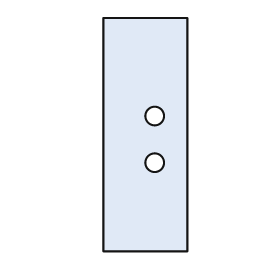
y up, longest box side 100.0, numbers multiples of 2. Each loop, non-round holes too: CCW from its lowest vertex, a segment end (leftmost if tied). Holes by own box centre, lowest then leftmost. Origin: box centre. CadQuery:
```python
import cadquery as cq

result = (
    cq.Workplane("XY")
    .moveTo(-18.0, -50.0)
    .lineTo(18.0, -50.0)
    .lineTo(18.0, 50.0)
    .lineTo(-18.0, 50.0)
    .close()
    .moveTo(4.0, -12.0)
    .circle(4.0)
    .moveTo(4.0, 8.0)
    .circle(4.0)
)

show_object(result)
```